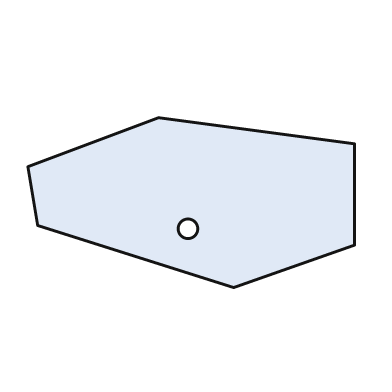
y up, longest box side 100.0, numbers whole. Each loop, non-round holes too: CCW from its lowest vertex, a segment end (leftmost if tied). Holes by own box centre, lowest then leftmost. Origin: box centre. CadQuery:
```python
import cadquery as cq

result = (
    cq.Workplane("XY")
    .moveTo(13.0, -26.0)
    .lineTo(50.0, -13.0)
    .lineTo(50.0, 18.0)
    .lineTo(-10.0, 26.0)
    .lineTo(-50.0, 11.0)
    .lineTo(-47.0, -7.0)
    .close()
    .moveTo(-1.0, -8.0)
    .circle(3.0)
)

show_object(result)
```